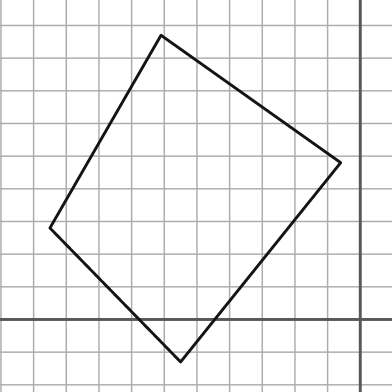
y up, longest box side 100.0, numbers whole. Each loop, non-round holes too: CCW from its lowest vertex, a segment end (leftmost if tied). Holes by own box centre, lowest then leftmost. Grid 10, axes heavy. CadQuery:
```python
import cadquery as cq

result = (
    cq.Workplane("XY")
    .moveTo(-55.0, -13.0)
    .lineTo(-6.0, 48.0)
    .lineTo(-61.0, 87.0)
    .lineTo(-95.0, 28.0)
    .close()
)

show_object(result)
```